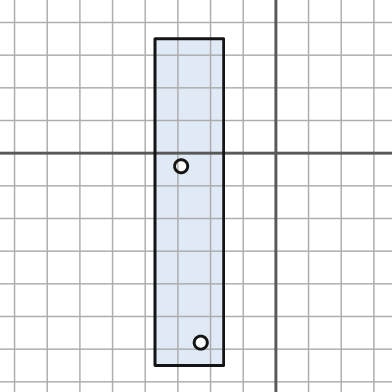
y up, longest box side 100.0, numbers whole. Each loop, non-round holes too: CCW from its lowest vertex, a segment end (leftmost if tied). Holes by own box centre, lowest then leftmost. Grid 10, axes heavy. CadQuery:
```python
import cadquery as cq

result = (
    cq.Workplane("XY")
    .moveTo(-37.0, -65.0)
    .lineTo(-16.0, -65.0)
    .lineTo(-16.0, 35.0)
    .lineTo(-37.0, 35.0)
    .close()
    .moveTo(-23.0, -58.0)
    .circle(2.0)
    .moveTo(-29.0, -4.0)
    .circle(2.0)
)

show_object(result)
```